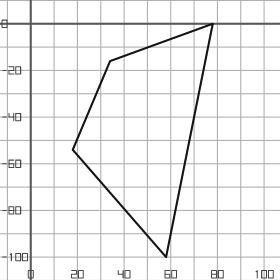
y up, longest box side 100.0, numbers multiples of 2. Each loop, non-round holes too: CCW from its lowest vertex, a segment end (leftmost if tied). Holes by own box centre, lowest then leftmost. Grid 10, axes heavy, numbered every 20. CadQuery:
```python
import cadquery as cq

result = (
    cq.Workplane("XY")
    .moveTo(58.0, -100.0)
    .lineTo(78.0, 0.0)
    .lineTo(34.0, -16.0)
    .lineTo(18.0, -54.0)
    .close()
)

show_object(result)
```